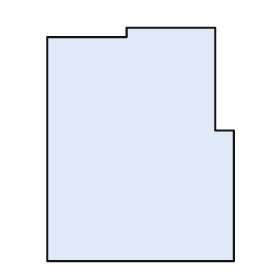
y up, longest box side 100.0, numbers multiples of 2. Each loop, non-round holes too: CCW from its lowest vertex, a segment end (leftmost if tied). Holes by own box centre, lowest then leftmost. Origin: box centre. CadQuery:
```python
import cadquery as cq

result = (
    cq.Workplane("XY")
    .moveTo(-40.0, -50.0)
    .lineTo(40.0, -50.0)
    .lineTo(40.0, 6.0)
    .lineTo(32.0, 6.0)
    .lineTo(32.0, 50.0)
    .lineTo(-6.0, 50.0)
    .lineTo(-6.0, 46.0)
    .lineTo(-40.0, 46.0)
    .close()
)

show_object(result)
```